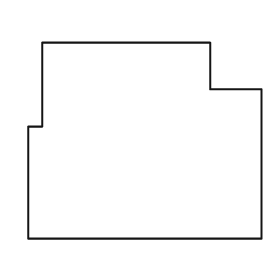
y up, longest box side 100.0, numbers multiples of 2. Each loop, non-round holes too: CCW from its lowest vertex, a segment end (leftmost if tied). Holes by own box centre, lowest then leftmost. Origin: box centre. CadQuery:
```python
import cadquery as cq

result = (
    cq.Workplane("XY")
    .moveTo(-50.0, -42.0)
    .lineTo(50.0, -42.0)
    .lineTo(50.0, 22.0)
    .lineTo(28.0, 22.0)
    .lineTo(28.0, 42.0)
    .lineTo(-44.0, 42.0)
    .lineTo(-44.0, 6.0)
    .lineTo(-50.0, 6.0)
    .close()
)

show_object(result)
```